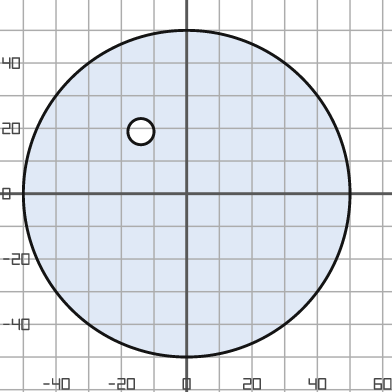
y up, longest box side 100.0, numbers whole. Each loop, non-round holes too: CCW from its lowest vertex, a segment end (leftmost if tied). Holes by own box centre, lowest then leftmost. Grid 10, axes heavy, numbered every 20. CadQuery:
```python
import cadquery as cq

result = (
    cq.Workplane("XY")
    .moveTo(0.0, 0.0)
    .circle(50.0)
    .moveTo(-14.0, 19.0)
    .circle(4.0)
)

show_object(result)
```